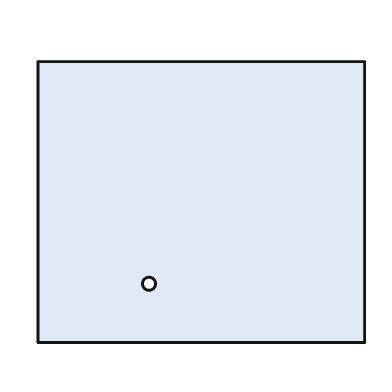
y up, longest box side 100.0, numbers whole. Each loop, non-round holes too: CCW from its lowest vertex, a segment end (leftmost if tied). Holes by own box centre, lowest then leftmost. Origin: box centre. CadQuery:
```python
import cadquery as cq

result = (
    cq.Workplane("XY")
    .moveTo(-50.0, -43.0)
    .lineTo(50.0, -43.0)
    .lineTo(50.0, 43.0)
    .lineTo(-50.0, 43.0)
    .close()
    .moveTo(-16.0, -25.0)
    .circle(2.0)
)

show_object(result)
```